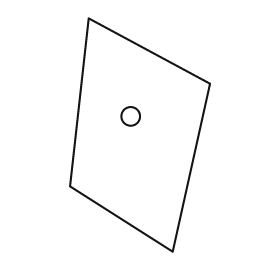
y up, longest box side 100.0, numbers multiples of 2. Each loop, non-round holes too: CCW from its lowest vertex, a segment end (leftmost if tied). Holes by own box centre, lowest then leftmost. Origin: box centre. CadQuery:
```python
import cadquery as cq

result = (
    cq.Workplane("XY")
    .moveTo(14.0, -50.0)
    .lineTo(30.0, 22.0)
    .lineTo(-22.0, 50.0)
    .lineTo(-30.0, -22.0)
    .close()
    .moveTo(-4.0, 8.0)
    .circle(4.0)
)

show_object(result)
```